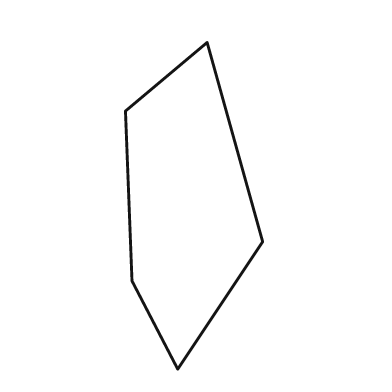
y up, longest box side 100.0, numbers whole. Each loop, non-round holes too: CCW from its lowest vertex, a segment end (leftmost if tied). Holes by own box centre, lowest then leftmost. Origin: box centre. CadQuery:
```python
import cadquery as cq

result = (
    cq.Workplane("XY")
    .moveTo(-5.0, -50.0)
    .lineTo(21.0, -11.0)
    .lineTo(4.0, 50.0)
    .lineTo(-21.0, 29.0)
    .lineTo(-19.0, -23.0)
    .close()
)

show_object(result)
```